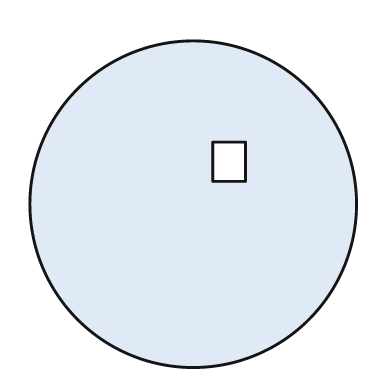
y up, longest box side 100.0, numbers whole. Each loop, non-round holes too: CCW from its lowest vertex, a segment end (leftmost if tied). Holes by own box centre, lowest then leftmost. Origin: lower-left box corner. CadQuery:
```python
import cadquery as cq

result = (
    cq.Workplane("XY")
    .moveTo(50.0, 50.0)
    .circle(50.0)
    .moveTo(56.0, 57.0)
    .lineTo(66.0, 57.0)
    .lineTo(66.0, 69.0)
    .lineTo(56.0, 69.0)
    .close()
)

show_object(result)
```